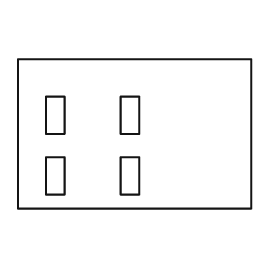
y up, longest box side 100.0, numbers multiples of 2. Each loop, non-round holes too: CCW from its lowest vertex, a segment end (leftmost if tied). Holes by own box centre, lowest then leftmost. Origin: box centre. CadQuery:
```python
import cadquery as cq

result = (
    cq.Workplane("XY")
    .moveTo(-50.0, -32.0)
    .lineTo(50.0, -32.0)
    .lineTo(50.0, 32.0)
    .lineTo(-50.0, 32.0)
    .close()
    .moveTo(-38.0, -26.0)
    .lineTo(-30.0, -26.0)
    .lineTo(-30.0, -10.0)
    .lineTo(-38.0, -10.0)
    .close()
    .moveTo(-6.0, -26.0)
    .lineTo(2.0, -26.0)
    .lineTo(2.0, -10.0)
    .lineTo(-6.0, -10.0)
    .close()
    .moveTo(-38.0, 0.0)
    .lineTo(-30.0, 0.0)
    .lineTo(-30.0, 16.0)
    .lineTo(-38.0, 16.0)
    .close()
    .moveTo(-6.0, 0.0)
    .lineTo(2.0, 0.0)
    .lineTo(2.0, 16.0)
    .lineTo(-6.0, 16.0)
    .close()
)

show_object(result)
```